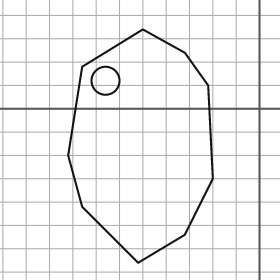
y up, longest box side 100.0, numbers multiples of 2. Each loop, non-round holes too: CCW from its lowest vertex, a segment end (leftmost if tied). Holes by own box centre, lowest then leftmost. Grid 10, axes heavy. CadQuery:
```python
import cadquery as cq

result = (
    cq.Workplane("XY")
    .moveTo(-52.0, -66.0)
    .lineTo(-32.0, -54.0)
    .lineTo(-20.0, -30.0)
    .lineTo(-22.0, 10.0)
    .lineTo(-32.0, 24.0)
    .lineTo(-50.0, 34.0)
    .lineTo(-76.0, 18.0)
    .lineTo(-82.0, -20.0)
    .lineTo(-76.0, -42.0)
    .close()
    .moveTo(-66.0, 12.0)
    .circle(6.0)
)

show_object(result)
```